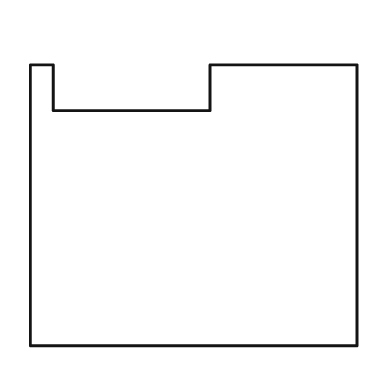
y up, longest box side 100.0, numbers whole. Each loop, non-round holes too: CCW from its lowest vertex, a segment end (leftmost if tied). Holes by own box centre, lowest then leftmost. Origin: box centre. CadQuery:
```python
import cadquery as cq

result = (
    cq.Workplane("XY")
    .moveTo(-50.0, -43.0)
    .lineTo(50.0, -43.0)
    .lineTo(50.0, 43.0)
    .lineTo(5.0, 43.0)
    .lineTo(5.0, 29.0)
    .lineTo(-43.0, 29.0)
    .lineTo(-43.0, 43.0)
    .lineTo(-50.0, 43.0)
    .close()
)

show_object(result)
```